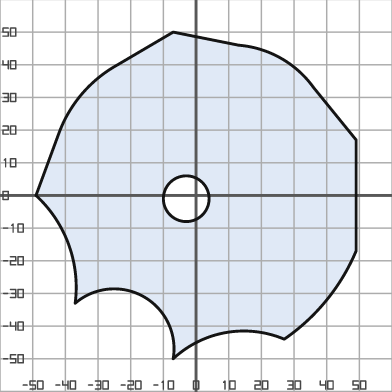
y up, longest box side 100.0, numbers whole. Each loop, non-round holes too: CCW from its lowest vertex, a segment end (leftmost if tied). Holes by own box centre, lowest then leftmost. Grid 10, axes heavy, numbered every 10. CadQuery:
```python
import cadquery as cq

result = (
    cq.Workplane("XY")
    .moveTo(-7.0, -50.0)
    .threePointArc((9.0, -42.0), (27.0, -44.0))
    .threePointArc((40.0, -32.0), (49.0, -17.0))
    .lineTo(49.0, 17.0)
    .lineTo(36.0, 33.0)
    .threePointArc((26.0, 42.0), (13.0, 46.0))
    .lineTo(-7.0, 50.0)
    .lineTo(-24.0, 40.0)
    .threePointArc((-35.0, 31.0), (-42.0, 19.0))
    .lineTo(-49.0, 0.0)
    .threePointArc((-39.0, -15.0), (-37.0, -33.0))
    .threePointArc((-16.0, -31.0), (-7.0, -50.0))
    .close()
    .moveTo(-3.0, -1.0)
    .circle(7.0)
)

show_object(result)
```